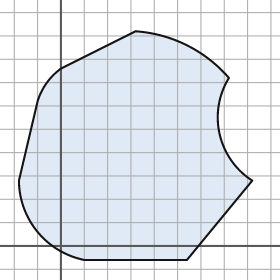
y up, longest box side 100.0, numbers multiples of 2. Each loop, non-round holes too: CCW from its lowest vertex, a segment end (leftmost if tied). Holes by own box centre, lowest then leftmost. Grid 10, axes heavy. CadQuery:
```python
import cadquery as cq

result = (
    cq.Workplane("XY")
    .moveTo(10.0, -6.0)
    .lineTo(54.0, -6.0)
    .lineTo(82.0, 28.0)
    .threePointArc((68.0, 48.0), (72.0, 72.0))
    .threePointArc((54.0, 86.0), (32.0, 92.0))
    .lineTo(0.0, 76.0)
    .threePointArc((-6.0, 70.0), (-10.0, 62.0))
    .lineTo(-18.0, 28.0)
    .threePointArc((-10.0, 6.0), (10.0, -6.0))
    .close()
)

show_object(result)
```